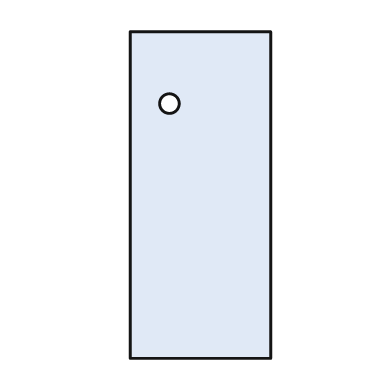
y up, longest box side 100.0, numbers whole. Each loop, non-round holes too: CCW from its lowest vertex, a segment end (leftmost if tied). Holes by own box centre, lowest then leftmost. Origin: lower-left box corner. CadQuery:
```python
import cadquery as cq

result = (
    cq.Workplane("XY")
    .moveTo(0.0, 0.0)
    .lineTo(43.0, 0.0)
    .lineTo(43.0, 100.0)
    .lineTo(0.0, 100.0)
    .close()
    .moveTo(12.0, 78.0)
    .circle(3.0)
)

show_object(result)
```